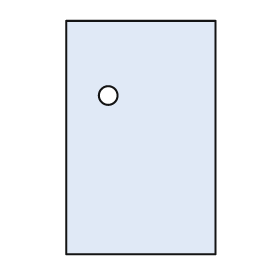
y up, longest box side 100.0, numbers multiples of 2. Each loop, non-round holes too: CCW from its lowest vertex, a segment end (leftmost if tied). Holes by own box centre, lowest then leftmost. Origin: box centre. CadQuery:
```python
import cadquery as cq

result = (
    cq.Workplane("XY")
    .moveTo(-32.0, -50.0)
    .lineTo(32.0, -50.0)
    .lineTo(32.0, 50.0)
    .lineTo(-32.0, 50.0)
    .close()
    .moveTo(-14.0, 18.0)
    .circle(4.0)
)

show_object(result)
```